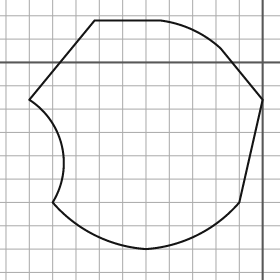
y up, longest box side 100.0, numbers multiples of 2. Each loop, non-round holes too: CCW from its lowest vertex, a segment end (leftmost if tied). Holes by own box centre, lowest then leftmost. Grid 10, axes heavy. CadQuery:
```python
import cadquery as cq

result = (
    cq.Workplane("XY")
    .moveTo(-50.0, -80.0)
    .threePointArc((-28.0, -74.0), (-10.0, -60.0))
    .lineTo(0.0, -16.0)
    .lineTo(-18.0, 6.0)
    .threePointArc((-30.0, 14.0), (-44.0, 18.0))
    .lineTo(-72.0, 18.0)
    .lineTo(-100.0, -16.0)
    .threePointArc((-86.0, -36.0), (-90.0, -60.0))
    .threePointArc((-72.0, -74.0), (-50.0, -80.0))
    .close()
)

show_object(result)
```